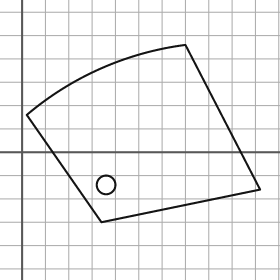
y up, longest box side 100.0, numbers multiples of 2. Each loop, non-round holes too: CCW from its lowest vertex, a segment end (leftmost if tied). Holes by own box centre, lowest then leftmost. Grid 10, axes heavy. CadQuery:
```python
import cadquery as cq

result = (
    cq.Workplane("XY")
    .moveTo(34.0, -30.0)
    .lineTo(102.0, -16.0)
    .lineTo(70.0, 46.0)
    .threePointArc((34.0, 36.0), (2.0, 16.0))
    .close()
    .moveTo(36.0, -14.0)
    .circle(4.0)
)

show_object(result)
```